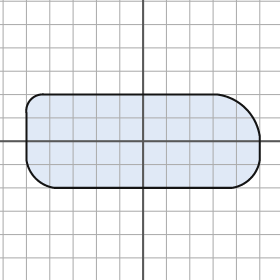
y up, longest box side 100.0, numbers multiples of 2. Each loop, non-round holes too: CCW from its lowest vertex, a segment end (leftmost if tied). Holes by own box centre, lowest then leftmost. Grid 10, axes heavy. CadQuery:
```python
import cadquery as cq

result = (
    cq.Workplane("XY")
    .moveTo(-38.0, -20.0)
    .lineTo(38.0, -20.0)
    .threePointArc((46.0, -16.0), (50.0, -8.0))
    .lineTo(50.0, 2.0)
    .threePointArc((44.0, 14.0), (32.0, 20.0))
    .lineTo(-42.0, 20.0)
    .threePointArc((-48.0, 18.0), (-50.0, 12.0))
    .lineTo(-50.0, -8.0)
    .threePointArc((-46.0, -16.0), (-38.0, -20.0))
    .close()
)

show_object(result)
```